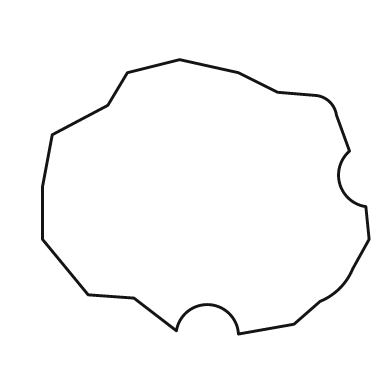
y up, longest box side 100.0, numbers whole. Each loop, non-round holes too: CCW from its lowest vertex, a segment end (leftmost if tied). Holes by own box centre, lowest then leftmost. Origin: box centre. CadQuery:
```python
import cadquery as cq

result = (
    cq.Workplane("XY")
    .moveTo(10.0, -42.0)
    .lineTo(27.0, -39.0)
    .lineTo(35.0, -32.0)
    .threePointArc((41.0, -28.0), (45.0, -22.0))
    .lineTo(50.0, -13.0)
    .lineTo(49.0, -3.0)
    .threePointArc((41.0, 4.0), (44.0, 14.0))
    .lineTo(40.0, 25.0)
    .threePointArc((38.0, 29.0), (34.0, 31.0))
    .lineTo(22.0, 32.0)
    .lineTo(10.0, 38.0)
    .lineTo(-8.0, 42.0)
    .lineTo(-24.0, 38.0)
    .lineTo(-30.0, 28.0)
    .lineTo(-47.0, 19.0)
    .lineTo(-50.0, 3.0)
    .lineTo(-50.0, -13.0)
    .lineTo(-36.0, -30.0)
    .lineTo(-22.0, -31.0)
    .lineTo(-9.0, -41.0)
    .threePointArc((1.0, -33.0), (10.0, -42.0))
    .close()
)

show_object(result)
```